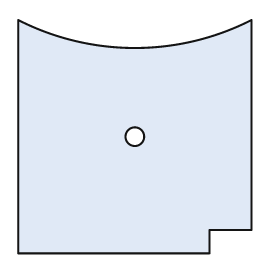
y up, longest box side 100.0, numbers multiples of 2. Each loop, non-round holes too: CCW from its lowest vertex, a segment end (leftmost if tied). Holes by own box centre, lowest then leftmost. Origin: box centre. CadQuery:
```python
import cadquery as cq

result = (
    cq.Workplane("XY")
    .moveTo(-50.0, -50.0)
    .lineTo(32.0, -50.0)
    .lineTo(32.0, -40.0)
    .lineTo(50.0, -40.0)
    .lineTo(50.0, 50.0)
    .threePointArc((0.0, 38.0), (-50.0, 50.0))
    .close()
    .moveTo(0.0, 0.0)
    .circle(4.0)
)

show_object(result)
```